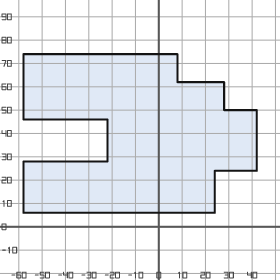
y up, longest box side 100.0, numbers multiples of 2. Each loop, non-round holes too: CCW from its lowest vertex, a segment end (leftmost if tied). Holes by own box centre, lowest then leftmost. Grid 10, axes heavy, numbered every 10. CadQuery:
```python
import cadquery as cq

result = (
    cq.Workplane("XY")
    .moveTo(-58.0, 6.0)
    .lineTo(24.0, 6.0)
    .lineTo(24.0, 24.0)
    .lineTo(42.0, 24.0)
    .lineTo(42.0, 50.0)
    .lineTo(28.0, 50.0)
    .lineTo(28.0, 62.0)
    .lineTo(8.0, 62.0)
    .lineTo(8.0, 74.0)
    .lineTo(-58.0, 74.0)
    .lineTo(-58.0, 46.0)
    .lineTo(-22.0, 46.0)
    .lineTo(-22.0, 28.0)
    .lineTo(-58.0, 28.0)
    .close()
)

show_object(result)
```